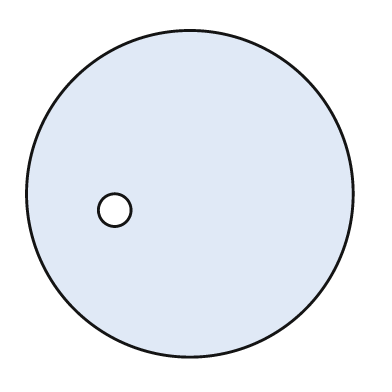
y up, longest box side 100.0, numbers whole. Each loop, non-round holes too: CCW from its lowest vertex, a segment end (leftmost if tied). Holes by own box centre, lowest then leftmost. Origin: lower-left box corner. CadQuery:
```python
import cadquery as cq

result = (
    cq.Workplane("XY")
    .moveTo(50.0, 50.0)
    .circle(50.0)
    .moveTo(27.0, 45.0)
    .circle(5.0)
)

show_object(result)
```